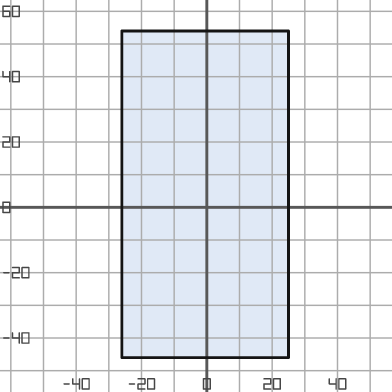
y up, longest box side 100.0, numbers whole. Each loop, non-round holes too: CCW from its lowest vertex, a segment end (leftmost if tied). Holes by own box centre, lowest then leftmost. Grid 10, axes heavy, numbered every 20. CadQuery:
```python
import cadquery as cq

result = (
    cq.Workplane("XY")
    .moveTo(-26.0, -46.0)
    .lineTo(25.0, -46.0)
    .lineTo(25.0, 54.0)
    .lineTo(-26.0, 54.0)
    .close()
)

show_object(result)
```